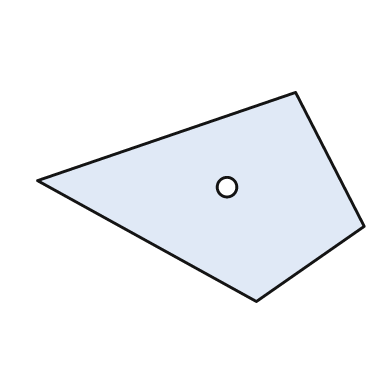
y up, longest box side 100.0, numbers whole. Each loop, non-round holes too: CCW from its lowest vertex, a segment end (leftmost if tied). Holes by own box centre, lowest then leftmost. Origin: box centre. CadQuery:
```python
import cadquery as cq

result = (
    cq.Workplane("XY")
    .moveTo(17.0, -32.0)
    .lineTo(50.0, -9.0)
    .lineTo(29.0, 32.0)
    .lineTo(-50.0, 5.0)
    .close()
    .moveTo(8.0, 3.0)
    .circle(3.0)
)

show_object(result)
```